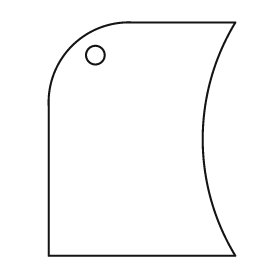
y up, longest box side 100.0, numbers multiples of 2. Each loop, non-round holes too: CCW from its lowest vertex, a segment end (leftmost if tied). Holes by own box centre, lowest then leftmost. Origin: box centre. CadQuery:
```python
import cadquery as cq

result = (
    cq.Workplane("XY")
    .moveTo(-40.0, -50.0)
    .lineTo(40.0, -50.0)
    .threePointArc((26.0, 0.0), (40.0, 50.0))
    .lineTo(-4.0, 50.0)
    .threePointArc((-30.0, 40.0), (-40.0, 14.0))
    .close()
    .moveTo(-20.0, 36.0)
    .circle(4.0)
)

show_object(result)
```